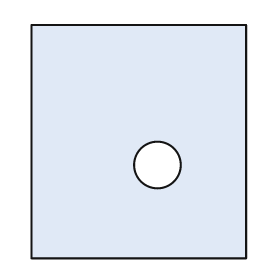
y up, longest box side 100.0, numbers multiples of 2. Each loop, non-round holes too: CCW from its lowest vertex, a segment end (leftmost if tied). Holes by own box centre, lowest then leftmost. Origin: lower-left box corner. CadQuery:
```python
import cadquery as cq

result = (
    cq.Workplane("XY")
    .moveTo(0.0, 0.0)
    .lineTo(92.0, 0.0)
    .lineTo(92.0, 100.0)
    .lineTo(0.0, 100.0)
    .close()
    .moveTo(54.0, 40.0)
    .circle(10.0)
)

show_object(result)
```